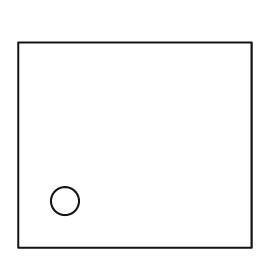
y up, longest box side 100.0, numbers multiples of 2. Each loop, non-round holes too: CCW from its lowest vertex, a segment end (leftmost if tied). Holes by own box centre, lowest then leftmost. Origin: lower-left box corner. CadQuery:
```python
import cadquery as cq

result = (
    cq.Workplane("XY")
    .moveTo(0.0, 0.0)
    .lineTo(100.0, 0.0)
    .lineTo(100.0, 88.0)
    .lineTo(0.0, 88.0)
    .close()
    .moveTo(20.0, 20.0)
    .circle(6.0)
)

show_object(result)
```